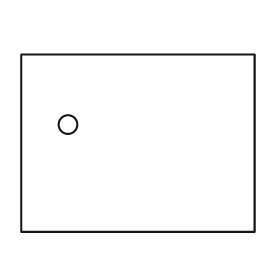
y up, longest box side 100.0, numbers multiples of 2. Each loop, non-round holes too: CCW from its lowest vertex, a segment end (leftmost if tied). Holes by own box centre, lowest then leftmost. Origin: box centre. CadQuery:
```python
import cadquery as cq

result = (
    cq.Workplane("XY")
    .moveTo(-50.0, -38.0)
    .lineTo(50.0, -38.0)
    .lineTo(50.0, 38.0)
    .lineTo(-50.0, 38.0)
    .close()
    .moveTo(-30.0, 8.0)
    .circle(4.0)
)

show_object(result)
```